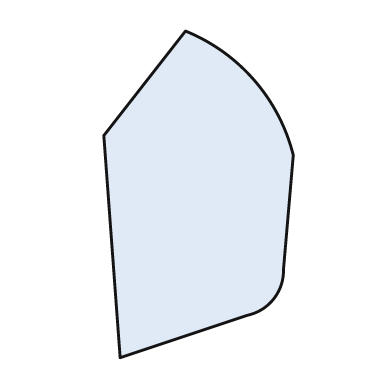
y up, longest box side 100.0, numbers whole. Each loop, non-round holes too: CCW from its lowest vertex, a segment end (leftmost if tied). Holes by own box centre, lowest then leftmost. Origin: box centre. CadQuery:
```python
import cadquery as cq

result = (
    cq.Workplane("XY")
    .moveTo(-24.0, -50.0)
    .lineTo(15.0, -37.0)
    .threePointArc((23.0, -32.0), (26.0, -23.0))
    .lineTo(29.0, 12.0)
    .threePointArc((17.0, 35.0), (-4.0, 50.0))
    .lineTo(-29.0, 18.0)
    .close()
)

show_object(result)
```